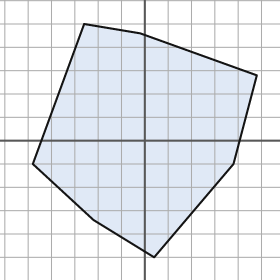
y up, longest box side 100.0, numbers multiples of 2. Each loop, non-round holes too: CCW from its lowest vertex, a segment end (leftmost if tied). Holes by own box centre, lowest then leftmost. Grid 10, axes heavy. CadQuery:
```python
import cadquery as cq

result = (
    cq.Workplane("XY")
    .moveTo(4.0, -50.0)
    .lineTo(38.0, -10.0)
    .lineTo(48.0, 28.0)
    .lineTo(-2.0, 46.0)
    .lineTo(-26.0, 50.0)
    .lineTo(-48.0, -10.0)
    .lineTo(-22.0, -34.0)
    .close()
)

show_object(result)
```